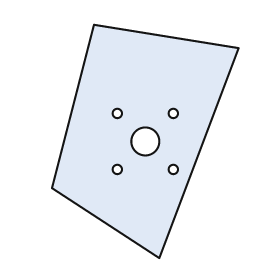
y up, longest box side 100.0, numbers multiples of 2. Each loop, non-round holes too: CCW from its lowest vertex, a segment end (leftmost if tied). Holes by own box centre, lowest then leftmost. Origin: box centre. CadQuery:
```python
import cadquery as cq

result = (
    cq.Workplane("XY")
    .moveTo(6.0, -50.0)
    .lineTo(40.0, 40.0)
    .lineTo(-22.0, 50.0)
    .lineTo(-40.0, -20.0)
    .close()
    .moveTo(-12.0, -12.0)
    .circle(2.0)
    .moveTo(12.0, -12.0)
    .circle(2.0)
    .moveTo(0.0, 0.0)
    .circle(6.0)
    .moveTo(-12.0, 12.0)
    .circle(2.0)
    .moveTo(12.0, 12.0)
    .circle(2.0)
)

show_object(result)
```